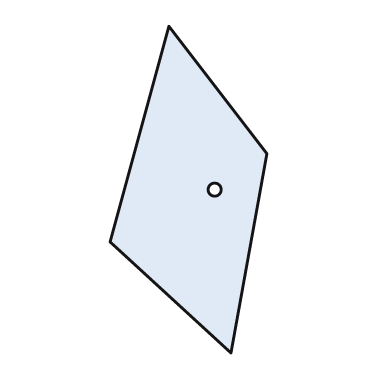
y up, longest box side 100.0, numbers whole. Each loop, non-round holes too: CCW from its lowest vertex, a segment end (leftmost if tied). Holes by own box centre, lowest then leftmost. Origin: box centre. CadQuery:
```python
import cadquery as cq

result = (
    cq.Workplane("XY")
    .moveTo(13.0, -50.0)
    .lineTo(24.0, 11.0)
    .lineTo(-6.0, 50.0)
    .lineTo(-24.0, -16.0)
    .close()
    .moveTo(8.0, 0.0)
    .circle(2.0)
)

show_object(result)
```